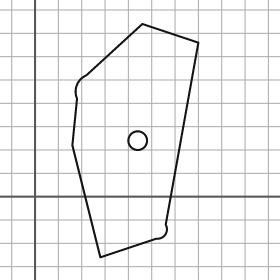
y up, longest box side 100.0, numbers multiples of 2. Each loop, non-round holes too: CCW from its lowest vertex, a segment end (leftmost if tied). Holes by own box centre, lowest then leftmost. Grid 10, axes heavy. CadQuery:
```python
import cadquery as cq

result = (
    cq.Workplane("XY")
    .moveTo(28.0, -26.0)
    .lineTo(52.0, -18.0)
    .threePointArc((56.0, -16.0), (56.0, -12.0))
    .lineTo(70.0, 66.0)
    .lineTo(46.0, 74.0)
    .lineTo(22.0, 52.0)
    .threePointArc((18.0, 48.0), (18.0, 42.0))
    .lineTo(16.0, 22.0)
    .close()
    .moveTo(44.0, 24.0)
    .circle(4.0)
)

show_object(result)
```